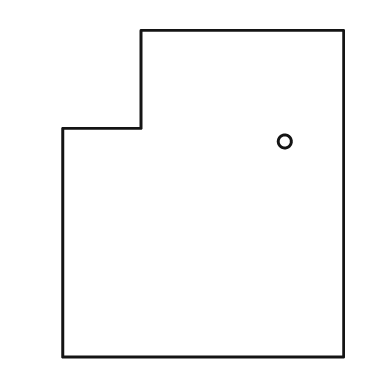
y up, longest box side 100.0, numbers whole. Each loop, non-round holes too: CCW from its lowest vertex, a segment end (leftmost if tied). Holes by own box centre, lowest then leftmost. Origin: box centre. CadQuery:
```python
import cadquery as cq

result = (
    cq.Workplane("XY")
    .moveTo(-43.0, -50.0)
    .lineTo(43.0, -50.0)
    .lineTo(43.0, 50.0)
    .lineTo(-19.0, 50.0)
    .lineTo(-19.0, 20.0)
    .lineTo(-43.0, 20.0)
    .close()
    .moveTo(25.0, 16.0)
    .circle(2.0)
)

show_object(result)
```